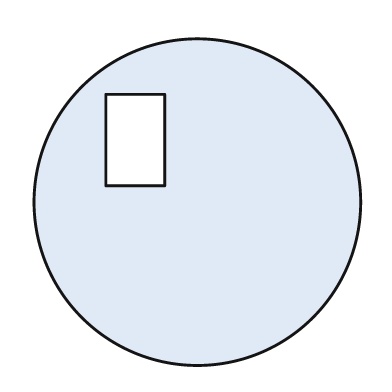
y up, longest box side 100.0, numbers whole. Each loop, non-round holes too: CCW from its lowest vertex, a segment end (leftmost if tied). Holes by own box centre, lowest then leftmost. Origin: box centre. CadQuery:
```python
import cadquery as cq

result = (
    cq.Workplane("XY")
    .moveTo(0.0, 0.0)
    .circle(50.0)
    .moveTo(-28.0, 5.0)
    .lineTo(-10.0, 5.0)
    .lineTo(-10.0, 33.0)
    .lineTo(-28.0, 33.0)
    .close()
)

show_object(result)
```